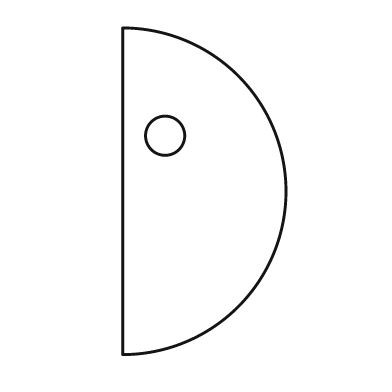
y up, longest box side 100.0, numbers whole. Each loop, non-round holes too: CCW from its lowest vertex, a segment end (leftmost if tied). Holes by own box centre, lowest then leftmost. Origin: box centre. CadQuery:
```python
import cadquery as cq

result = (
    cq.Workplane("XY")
    .moveTo(-25.0, -50.0)
    .threePointArc((25.0, 0.0), (-25.0, 50.0))
    .close()
    .moveTo(-12.0, 17.0)
    .circle(6.0)
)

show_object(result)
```